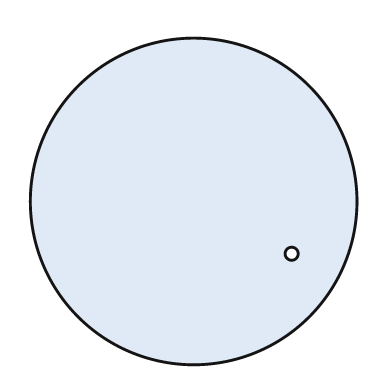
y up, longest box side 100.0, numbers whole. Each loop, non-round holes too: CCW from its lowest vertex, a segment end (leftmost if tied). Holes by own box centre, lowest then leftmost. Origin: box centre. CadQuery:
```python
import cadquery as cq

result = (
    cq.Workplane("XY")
    .moveTo(0.0, 0.0)
    .circle(50.0)
    .moveTo(30.0, -16.0)
    .circle(2.0)
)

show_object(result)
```